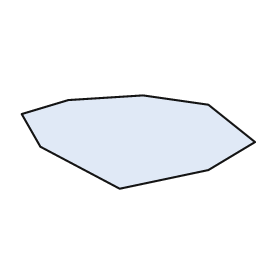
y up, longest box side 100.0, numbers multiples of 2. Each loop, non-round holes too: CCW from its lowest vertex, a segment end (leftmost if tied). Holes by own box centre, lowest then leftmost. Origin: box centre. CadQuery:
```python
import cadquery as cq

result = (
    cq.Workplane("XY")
    .moveTo(-8.0, -20.0)
    .lineTo(30.0, -12.0)
    .lineTo(50.0, 0.0)
    .lineTo(30.0, 16.0)
    .lineTo(2.0, 20.0)
    .lineTo(-30.0, 18.0)
    .lineTo(-50.0, 12.0)
    .lineTo(-42.0, -2.0)
    .close()
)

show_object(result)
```